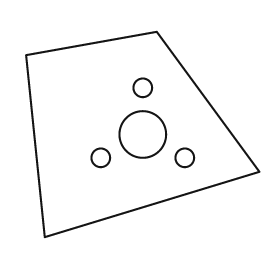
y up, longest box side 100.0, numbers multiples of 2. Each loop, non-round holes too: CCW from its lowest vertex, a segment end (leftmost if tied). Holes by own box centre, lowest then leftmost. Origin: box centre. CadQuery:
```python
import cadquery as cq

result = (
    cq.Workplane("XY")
    .moveTo(-42.0, -44.0)
    .lineTo(50.0, -16.0)
    .lineTo(6.0, 44.0)
    .lineTo(-50.0, 34.0)
    .close()
    .moveTo(-18.0, -10.0)
    .circle(4.0)
    .moveTo(18.0, -10.0)
    .circle(4.0)
    .moveTo(0.0, 0.0)
    .circle(10.0)
    .moveTo(0.0, 20.0)
    .circle(4.0)
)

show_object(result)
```